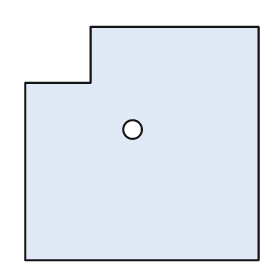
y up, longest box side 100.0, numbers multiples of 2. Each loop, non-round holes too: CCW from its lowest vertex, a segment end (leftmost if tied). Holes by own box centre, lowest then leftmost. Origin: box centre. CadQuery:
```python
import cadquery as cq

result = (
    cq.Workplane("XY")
    .moveTo(-50.0, -50.0)
    .lineTo(50.0, -50.0)
    .lineTo(50.0, 50.0)
    .lineTo(-22.0, 50.0)
    .lineTo(-22.0, 26.0)
    .lineTo(-50.0, 26.0)
    .close()
    .moveTo(-4.0, 6.0)
    .circle(4.0)
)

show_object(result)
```